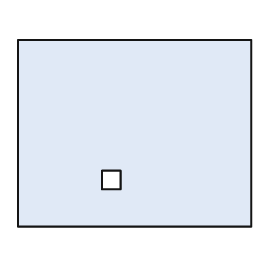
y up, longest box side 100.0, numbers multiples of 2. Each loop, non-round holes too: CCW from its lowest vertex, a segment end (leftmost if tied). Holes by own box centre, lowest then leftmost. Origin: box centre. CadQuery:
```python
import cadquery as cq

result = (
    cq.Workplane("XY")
    .moveTo(-50.0, -40.0)
    .lineTo(50.0, -40.0)
    .lineTo(50.0, 40.0)
    .lineTo(-50.0, 40.0)
    .close()
    .moveTo(-14.0, -24.0)
    .lineTo(-6.0, -24.0)
    .lineTo(-6.0, -16.0)
    .lineTo(-14.0, -16.0)
    .close()
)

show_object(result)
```